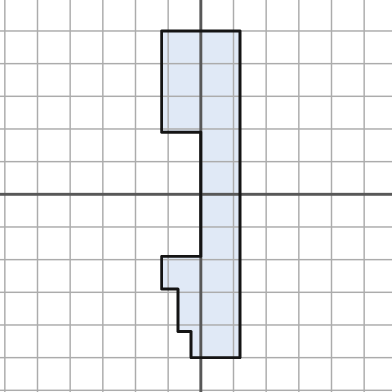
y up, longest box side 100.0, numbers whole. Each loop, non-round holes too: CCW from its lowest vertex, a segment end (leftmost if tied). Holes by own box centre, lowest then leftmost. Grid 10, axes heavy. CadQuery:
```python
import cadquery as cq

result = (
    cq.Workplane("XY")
    .moveTo(-3.0, -50.0)
    .lineTo(12.0, -50.0)
    .lineTo(12.0, 50.0)
    .lineTo(-12.0, 50.0)
    .lineTo(-12.0, 19.0)
    .lineTo(0.0, 19.0)
    .lineTo(0.0, -19.0)
    .lineTo(-12.0, -19.0)
    .lineTo(-12.0, -29.0)
    .lineTo(-7.0, -29.0)
    .lineTo(-7.0, -42.0)
    .lineTo(-3.0, -42.0)
    .close()
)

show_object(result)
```